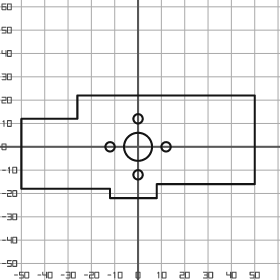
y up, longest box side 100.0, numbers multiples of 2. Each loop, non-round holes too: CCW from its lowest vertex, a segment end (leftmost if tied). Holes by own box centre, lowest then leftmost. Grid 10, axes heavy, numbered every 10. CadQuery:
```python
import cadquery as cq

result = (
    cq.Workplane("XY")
    .moveTo(-12.0, -22.0)
    .lineTo(8.0, -22.0)
    .lineTo(8.0, -16.0)
    .lineTo(50.0, -16.0)
    .lineTo(50.0, 22.0)
    .lineTo(-26.0, 22.0)
    .lineTo(-26.0, 12.0)
    .lineTo(-50.0, 12.0)
    .lineTo(-50.0, -18.0)
    .lineTo(-12.0, -18.0)
    .close()
    .moveTo(0.0, -12.0)
    .circle(2.0)
    .moveTo(-12.0, 0.0)
    .circle(2.0)
    .moveTo(0.0, 0.0)
    .circle(6.0)
    .moveTo(12.0, 0.0)
    .circle(2.0)
    .moveTo(0.0, 12.0)
    .circle(2.0)
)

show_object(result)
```